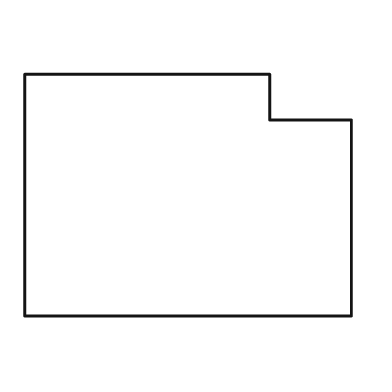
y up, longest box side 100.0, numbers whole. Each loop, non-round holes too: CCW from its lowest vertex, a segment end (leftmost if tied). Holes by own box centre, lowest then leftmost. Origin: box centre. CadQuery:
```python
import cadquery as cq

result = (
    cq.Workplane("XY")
    .moveTo(-50.0, -37.0)
    .lineTo(50.0, -37.0)
    .lineTo(50.0, 23.0)
    .lineTo(25.0, 23.0)
    .lineTo(25.0, 37.0)
    .lineTo(-50.0, 37.0)
    .close()
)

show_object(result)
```